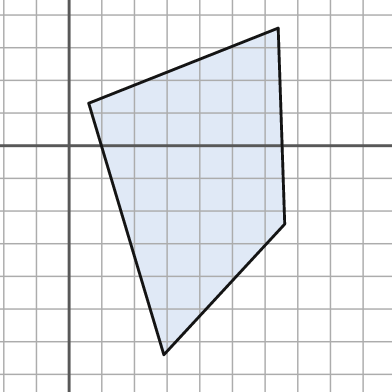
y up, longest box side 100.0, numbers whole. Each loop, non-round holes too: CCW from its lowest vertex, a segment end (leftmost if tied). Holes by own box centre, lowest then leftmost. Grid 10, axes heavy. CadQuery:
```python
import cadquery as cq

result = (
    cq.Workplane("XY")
    .moveTo(29.0, -64.0)
    .lineTo(66.0, -24.0)
    .lineTo(64.0, 36.0)
    .lineTo(6.0, 13.0)
    .close()
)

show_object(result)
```